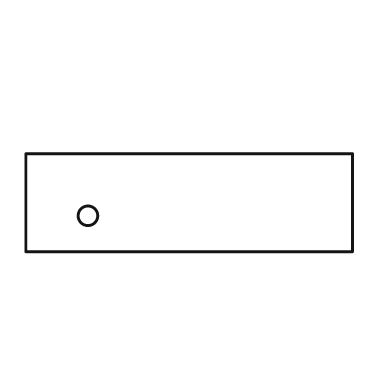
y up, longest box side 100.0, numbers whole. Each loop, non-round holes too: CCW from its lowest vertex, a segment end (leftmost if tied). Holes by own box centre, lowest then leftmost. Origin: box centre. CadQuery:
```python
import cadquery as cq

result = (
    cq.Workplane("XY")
    .moveTo(-50.0, -15.0)
    .lineTo(50.0, -15.0)
    .lineTo(50.0, 15.0)
    .lineTo(-50.0, 15.0)
    .close()
    .moveTo(-31.0, -4.0)
    .circle(3.0)
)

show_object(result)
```